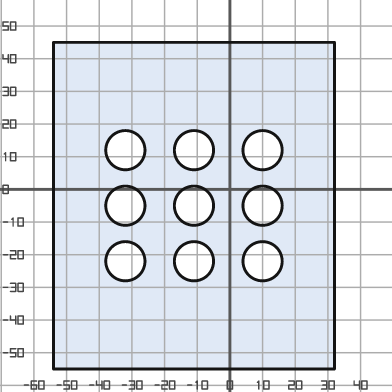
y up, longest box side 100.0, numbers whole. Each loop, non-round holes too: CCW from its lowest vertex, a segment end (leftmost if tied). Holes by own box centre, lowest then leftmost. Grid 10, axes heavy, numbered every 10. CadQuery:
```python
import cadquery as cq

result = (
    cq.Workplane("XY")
    .moveTo(-54.0, -55.0)
    .lineTo(32.0, -55.0)
    .lineTo(32.0, 45.0)
    .lineTo(-54.0, 45.0)
    .close()
    .moveTo(-32.0, -22.0)
    .circle(6.0)
    .moveTo(-11.0, -22.0)
    .circle(6.0)
    .moveTo(10.0, -22.0)
    .circle(6.0)
    .moveTo(-32.0, -5.0)
    .circle(6.0)
    .moveTo(-11.0, -5.0)
    .circle(6.0)
    .moveTo(10.0, -5.0)
    .circle(6.0)
    .moveTo(-32.0, 12.0)
    .circle(6.0)
    .moveTo(-11.0, 12.0)
    .circle(6.0)
    .moveTo(10.0, 12.0)
    .circle(6.0)
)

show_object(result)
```